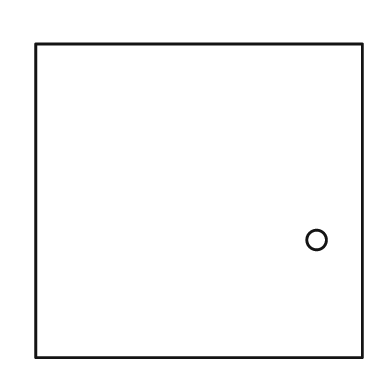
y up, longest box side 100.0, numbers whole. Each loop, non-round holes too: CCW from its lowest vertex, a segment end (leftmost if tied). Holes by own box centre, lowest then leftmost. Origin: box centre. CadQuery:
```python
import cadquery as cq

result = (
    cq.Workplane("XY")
    .moveTo(-50.0, -48.0)
    .lineTo(50.0, -48.0)
    .lineTo(50.0, 48.0)
    .lineTo(-50.0, 48.0)
    .close()
    .moveTo(36.0, -12.0)
    .circle(3.0)
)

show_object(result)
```